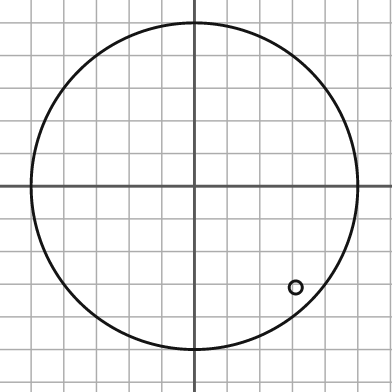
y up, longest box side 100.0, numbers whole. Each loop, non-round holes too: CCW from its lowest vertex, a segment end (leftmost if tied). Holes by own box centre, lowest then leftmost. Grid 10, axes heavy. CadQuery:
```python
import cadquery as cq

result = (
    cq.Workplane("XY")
    .moveTo(0.0, 0.0)
    .circle(50.0)
    .moveTo(31.0, -31.0)
    .circle(2.0)
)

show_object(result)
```